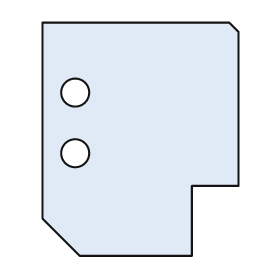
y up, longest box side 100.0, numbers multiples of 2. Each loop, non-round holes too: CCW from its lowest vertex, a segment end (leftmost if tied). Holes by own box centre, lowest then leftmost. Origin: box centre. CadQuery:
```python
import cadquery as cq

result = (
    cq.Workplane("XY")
    .moveTo(-26.0, -50.0)
    .lineTo(22.0, -50.0)
    .lineTo(22.0, -20.0)
    .lineTo(42.0, -20.0)
    .lineTo(42.0, 46.0)
    .lineTo(38.0, 50.0)
    .lineTo(-42.0, 50.0)
    .lineTo(-42.0, -34.0)
    .close()
    .moveTo(-28.0, -6.0)
    .circle(6.0)
    .moveTo(-28.0, 20.0)
    .circle(6.0)
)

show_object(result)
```